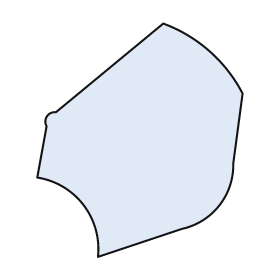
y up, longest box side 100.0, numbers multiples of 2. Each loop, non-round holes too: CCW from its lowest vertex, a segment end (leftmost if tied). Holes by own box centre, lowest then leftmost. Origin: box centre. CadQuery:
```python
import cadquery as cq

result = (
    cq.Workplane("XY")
    .moveTo(-18.0, -50.0)
    .lineTo(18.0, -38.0)
    .threePointArc((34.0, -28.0), (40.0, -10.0))
    .lineTo(44.0, 20.0)
    .threePointArc((30.0, 38.0), (10.0, 50.0))
    .lineTo(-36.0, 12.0)
    .threePointArc((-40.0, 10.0), (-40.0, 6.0))
    .lineTo(-44.0, -16.0)
    .threePointArc((-24.0, -28.0), (-18.0, -50.0))
    .close()
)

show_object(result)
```